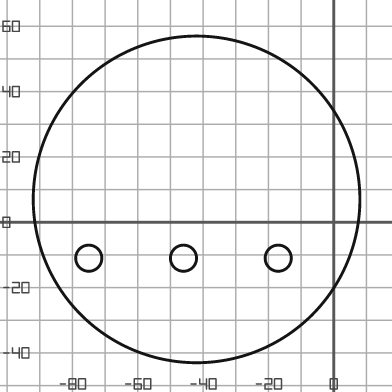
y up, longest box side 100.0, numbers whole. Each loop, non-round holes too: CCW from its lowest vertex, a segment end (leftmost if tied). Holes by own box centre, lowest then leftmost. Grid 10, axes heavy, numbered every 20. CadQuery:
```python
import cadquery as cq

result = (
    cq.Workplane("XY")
    .moveTo(-42.0, 7.0)
    .circle(50.0)
    .moveTo(-75.0, -11.0)
    .circle(4.0)
    .moveTo(-46.0, -11.0)
    .circle(4.0)
    .moveTo(-17.0, -11.0)
    .circle(4.0)
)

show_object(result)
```